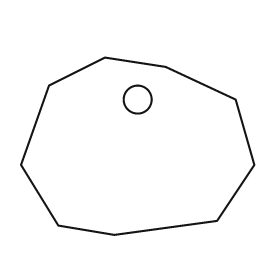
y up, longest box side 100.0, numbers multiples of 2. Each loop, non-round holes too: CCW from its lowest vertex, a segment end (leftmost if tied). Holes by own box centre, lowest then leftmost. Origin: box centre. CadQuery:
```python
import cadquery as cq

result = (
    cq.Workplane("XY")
    .moveTo(-10.0, -38.0)
    .lineTo(34.0, -32.0)
    .lineTo(50.0, -8.0)
    .lineTo(42.0, 20.0)
    .lineTo(12.0, 34.0)
    .lineTo(-14.0, 38.0)
    .lineTo(-38.0, 26.0)
    .lineTo(-50.0, -8.0)
    .lineTo(-34.0, -34.0)
    .close()
    .moveTo(0.0, 20.0)
    .circle(6.0)
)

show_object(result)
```